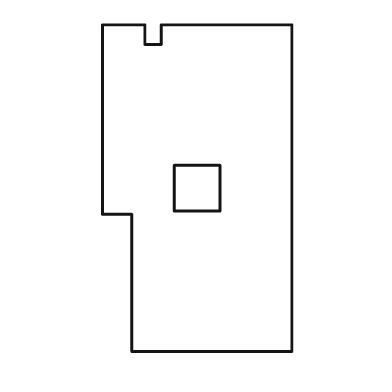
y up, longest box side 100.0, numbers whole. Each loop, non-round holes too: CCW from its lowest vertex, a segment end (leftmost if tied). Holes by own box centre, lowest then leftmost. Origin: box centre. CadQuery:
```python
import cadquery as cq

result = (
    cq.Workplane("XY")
    .moveTo(-20.0, -50.0)
    .lineTo(29.0, -50.0)
    .lineTo(29.0, 50.0)
    .lineTo(-11.0, 50.0)
    .lineTo(-11.0, 44.0)
    .lineTo(-16.0, 44.0)
    .lineTo(-16.0, 50.0)
    .lineTo(-29.0, 50.0)
    .lineTo(-29.0, -8.0)
    .lineTo(-20.0, -8.0)
    .close()
    .moveTo(-7.0, -7.0)
    .lineTo(7.0, -7.0)
    .lineTo(7.0, 7.0)
    .lineTo(-7.0, 7.0)
    .close()
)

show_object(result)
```